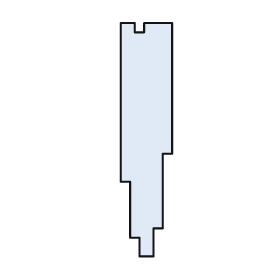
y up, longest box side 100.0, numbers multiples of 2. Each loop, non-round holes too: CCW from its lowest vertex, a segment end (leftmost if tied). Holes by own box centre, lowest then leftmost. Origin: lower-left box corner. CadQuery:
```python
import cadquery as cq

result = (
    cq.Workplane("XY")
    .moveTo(8.0, 0.0)
    .lineTo(14.0, 0.0)
    .lineTo(14.0, 12.0)
    .lineTo(18.0, 12.0)
    .lineTo(18.0, 44.0)
    .lineTo(22.0, 44.0)
    .lineTo(22.0, 100.0)
    .lineTo(10.0, 100.0)
    .lineTo(10.0, 96.0)
    .lineTo(6.0, 96.0)
    .lineTo(6.0, 100.0)
    .lineTo(0.0, 100.0)
    .lineTo(0.0, 32.0)
    .lineTo(4.0, 32.0)
    .lineTo(4.0, 8.0)
    .lineTo(8.0, 8.0)
    .close()
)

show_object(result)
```